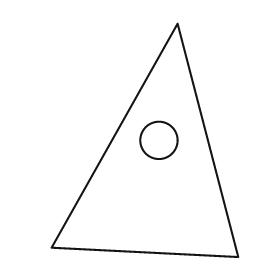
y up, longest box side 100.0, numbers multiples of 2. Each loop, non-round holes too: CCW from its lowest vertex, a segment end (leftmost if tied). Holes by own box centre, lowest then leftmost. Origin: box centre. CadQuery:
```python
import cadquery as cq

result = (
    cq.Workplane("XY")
    .moveTo(40.0, -50.0)
    .lineTo(14.0, 50.0)
    .lineTo(-40.0, -46.0)
    .close()
    .moveTo(6.0, 0.0)
    .circle(8.0)
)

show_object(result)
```